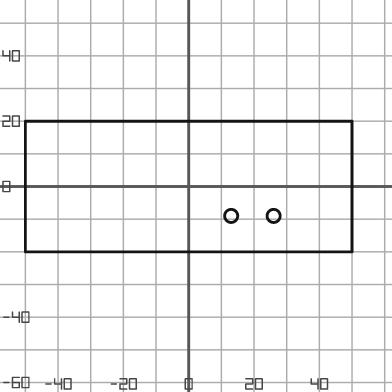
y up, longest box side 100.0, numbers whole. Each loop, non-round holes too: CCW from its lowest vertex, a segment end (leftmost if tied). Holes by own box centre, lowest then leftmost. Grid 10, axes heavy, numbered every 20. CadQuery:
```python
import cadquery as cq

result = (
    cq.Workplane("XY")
    .moveTo(-50.0, -20.0)
    .lineTo(50.0, -20.0)
    .lineTo(50.0, 20.0)
    .lineTo(-50.0, 20.0)
    .close()
    .moveTo(13.0, -9.0)
    .circle(2.0)
    .moveTo(26.0, -9.0)
    .circle(2.0)
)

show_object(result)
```